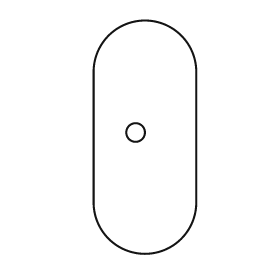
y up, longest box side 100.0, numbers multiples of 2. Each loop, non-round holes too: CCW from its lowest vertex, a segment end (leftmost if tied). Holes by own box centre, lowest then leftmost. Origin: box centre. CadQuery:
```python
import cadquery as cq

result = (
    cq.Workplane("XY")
    .moveTo(-22.0, -28.0)
    .threePointArc((0.0, -50.0), (22.0, -28.0))
    .lineTo(22.0, 28.0)
    .threePointArc((0.0, 50.0), (-22.0, 28.0))
    .close()
    .moveTo(-4.0, 2.0)
    .circle(4.0)
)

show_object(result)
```